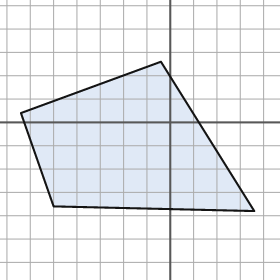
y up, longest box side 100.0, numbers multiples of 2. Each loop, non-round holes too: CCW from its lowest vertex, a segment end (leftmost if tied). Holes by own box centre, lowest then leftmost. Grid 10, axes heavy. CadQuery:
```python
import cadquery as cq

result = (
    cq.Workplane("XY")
    .moveTo(36.0, -38.0)
    .lineTo(-4.0, 26.0)
    .lineTo(-64.0, 4.0)
    .lineTo(-50.0, -36.0)
    .close()
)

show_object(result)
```